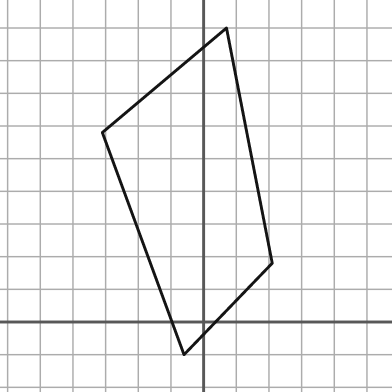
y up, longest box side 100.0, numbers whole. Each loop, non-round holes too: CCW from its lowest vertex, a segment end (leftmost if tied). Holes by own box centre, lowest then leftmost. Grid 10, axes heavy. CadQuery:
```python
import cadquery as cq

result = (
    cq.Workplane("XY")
    .moveTo(-6.0, -10.0)
    .lineTo(21.0, 18.0)
    .lineTo(7.0, 90.0)
    .lineTo(-31.0, 58.0)
    .close()
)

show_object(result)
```